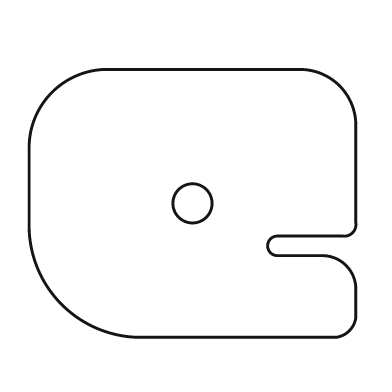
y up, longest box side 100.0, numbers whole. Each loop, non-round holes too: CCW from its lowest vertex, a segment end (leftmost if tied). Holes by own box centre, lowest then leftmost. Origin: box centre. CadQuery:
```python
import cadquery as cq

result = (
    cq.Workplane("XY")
    .moveTo(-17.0, -41.0)
    .lineTo(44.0, -41.0)
    .threePointArc((48.0, -39.0), (50.0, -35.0))
    .lineTo(50.0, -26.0)
    .threePointArc((47.0, -19.0), (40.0, -16.0))
    .lineTo(26.0, -16.0)
    .threePointArc((23.0, -13.0), (26.0, -10.0))
    .lineTo(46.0, -10.0)
    .threePointArc((49.0, -9.0), (50.0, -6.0))
    .lineTo(50.0, 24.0)
    .threePointArc((45.0, 36.0), (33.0, 41.0))
    .lineTo(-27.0, 41.0)
    .threePointArc((-43.0, 34.0), (-50.0, 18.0))
    .lineTo(-50.0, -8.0)
    .threePointArc((-40.0, -31.0), (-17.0, -41.0))
    .close()
    .moveTo(0.0, 0.0)
    .circle(6.0)
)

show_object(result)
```